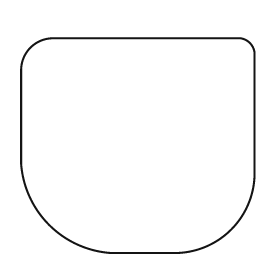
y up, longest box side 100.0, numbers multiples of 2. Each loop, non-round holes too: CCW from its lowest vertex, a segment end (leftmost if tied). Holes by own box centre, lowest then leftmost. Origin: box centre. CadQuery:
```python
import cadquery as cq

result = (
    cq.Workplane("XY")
    .moveTo(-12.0, -46.0)
    .lineTo(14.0, -46.0)
    .threePointArc((40.0, -36.0), (50.0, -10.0))
    .lineTo(50.0, 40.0)
    .threePointArc((48.0, 44.0), (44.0, 46.0))
    .lineTo(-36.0, 46.0)
    .threePointArc((-46.0, 42.0), (-50.0, 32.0))
    .lineTo(-50.0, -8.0)
    .threePointArc((-38.0, -34.0), (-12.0, -46.0))
    .close()
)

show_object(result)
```